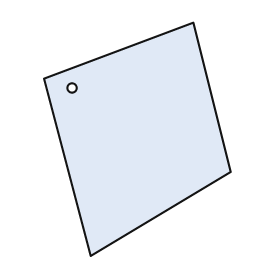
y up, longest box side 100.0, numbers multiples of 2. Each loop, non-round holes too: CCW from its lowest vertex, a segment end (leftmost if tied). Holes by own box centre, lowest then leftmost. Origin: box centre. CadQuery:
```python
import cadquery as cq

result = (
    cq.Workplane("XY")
    .moveTo(-20.0, -50.0)
    .lineTo(40.0, -14.0)
    .lineTo(24.0, 50.0)
    .lineTo(-40.0, 26.0)
    .close()
    .moveTo(-28.0, 22.0)
    .circle(2.0)
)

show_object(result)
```